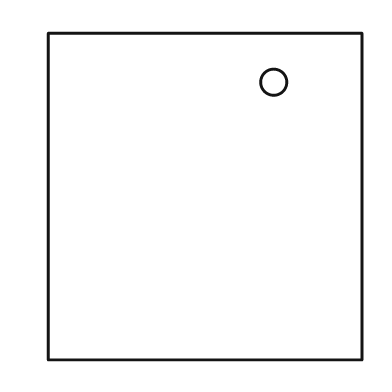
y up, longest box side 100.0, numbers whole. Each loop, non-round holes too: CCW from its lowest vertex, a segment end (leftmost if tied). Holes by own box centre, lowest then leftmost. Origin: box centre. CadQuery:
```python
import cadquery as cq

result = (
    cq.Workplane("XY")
    .moveTo(-48.0, -50.0)
    .lineTo(48.0, -50.0)
    .lineTo(48.0, 50.0)
    .lineTo(-48.0, 50.0)
    .close()
    .moveTo(21.0, 35.0)
    .circle(4.0)
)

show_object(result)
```